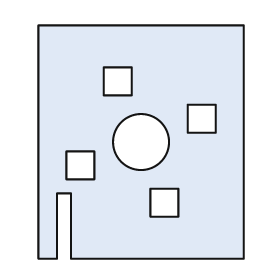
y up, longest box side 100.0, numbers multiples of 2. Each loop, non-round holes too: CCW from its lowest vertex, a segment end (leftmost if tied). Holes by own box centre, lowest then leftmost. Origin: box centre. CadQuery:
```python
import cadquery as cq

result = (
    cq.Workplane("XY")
    .moveTo(-44.0, -50.0)
    .lineTo(-36.0, -50.0)
    .lineTo(-36.0, -22.0)
    .lineTo(-30.0, -22.0)
    .lineTo(-30.0, -50.0)
    .lineTo(44.0, -50.0)
    .lineTo(44.0, 50.0)
    .lineTo(-44.0, 50.0)
    .close()
    .moveTo(4.0, -32.0)
    .lineTo(16.0, -32.0)
    .lineTo(16.0, -20.0)
    .lineTo(4.0, -20.0)
    .close()
    .moveTo(-32.0, -16.0)
    .lineTo(-20.0, -16.0)
    .lineTo(-20.0, -4.0)
    .lineTo(-32.0, -4.0)
    .close()
    .moveTo(0.0, 0.0)
    .circle(12.0)
    .moveTo(20.0, 4.0)
    .lineTo(32.0, 4.0)
    .lineTo(32.0, 16.0)
    .lineTo(20.0, 16.0)
    .close()
    .moveTo(-16.0, 20.0)
    .lineTo(-4.0, 20.0)
    .lineTo(-4.0, 32.0)
    .lineTo(-16.0, 32.0)
    .close()
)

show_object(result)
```